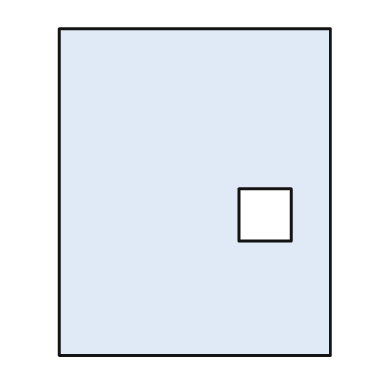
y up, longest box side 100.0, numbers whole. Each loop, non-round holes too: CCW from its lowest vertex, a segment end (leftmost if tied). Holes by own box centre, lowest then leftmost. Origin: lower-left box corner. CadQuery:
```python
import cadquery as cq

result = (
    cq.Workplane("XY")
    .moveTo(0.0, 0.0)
    .lineTo(83.0, 0.0)
    .lineTo(83.0, 100.0)
    .lineTo(0.0, 100.0)
    .close()
    .moveTo(55.0, 35.0)
    .lineTo(71.0, 35.0)
    .lineTo(71.0, 51.0)
    .lineTo(55.0, 51.0)
    .close()
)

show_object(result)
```